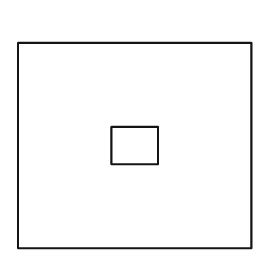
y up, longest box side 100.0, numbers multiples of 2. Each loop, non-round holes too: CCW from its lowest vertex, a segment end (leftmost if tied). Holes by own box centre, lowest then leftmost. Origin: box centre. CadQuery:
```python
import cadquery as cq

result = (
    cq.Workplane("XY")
    .moveTo(-50.0, -44.0)
    .lineTo(50.0, -44.0)
    .lineTo(50.0, 44.0)
    .lineTo(-50.0, 44.0)
    .close()
    .moveTo(-10.0, -8.0)
    .lineTo(10.0, -8.0)
    .lineTo(10.0, 8.0)
    .lineTo(-10.0, 8.0)
    .close()
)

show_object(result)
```